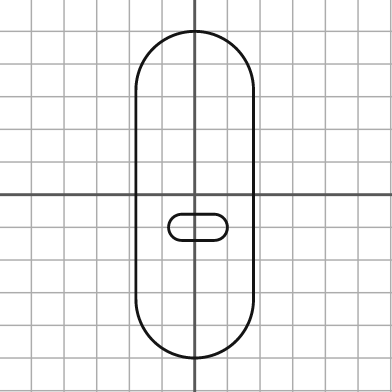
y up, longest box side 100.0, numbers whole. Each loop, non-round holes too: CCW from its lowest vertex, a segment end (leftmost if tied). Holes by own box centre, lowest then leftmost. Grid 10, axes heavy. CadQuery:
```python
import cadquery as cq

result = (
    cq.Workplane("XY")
    .moveTo(-18.0, -32.0)
    .threePointArc((0.0, -50.0), (18.0, -32.0))
    .lineTo(18.0, 32.0)
    .threePointArc((0.0, 50.0), (-18.0, 32.0))
    .close()
    .moveTo(-4.0, -14.0)
    .lineTo(6.0, -14.0)
    .threePointArc((10.0, -10.0), (6.0, -6.0))
    .lineTo(-4.0, -6.0)
    .threePointArc((-8.0, -10.0), (-4.0, -14.0))
    .close()
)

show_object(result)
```